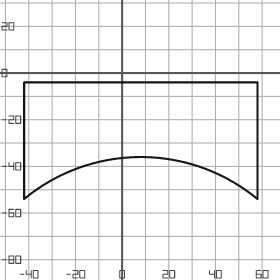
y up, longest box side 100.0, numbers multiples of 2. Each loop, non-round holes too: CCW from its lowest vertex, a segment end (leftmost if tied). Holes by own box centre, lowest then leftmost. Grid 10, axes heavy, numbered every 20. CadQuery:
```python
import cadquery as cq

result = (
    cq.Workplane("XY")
    .moveTo(-42.0, -54.0)
    .threePointArc((8.0, -36.0), (58.0, -54.0))
    .lineTo(58.0, -4.0)
    .lineTo(-42.0, -4.0)
    .close()
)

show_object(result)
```